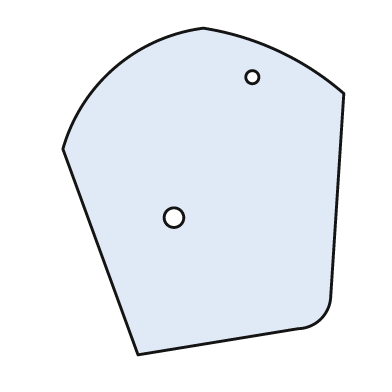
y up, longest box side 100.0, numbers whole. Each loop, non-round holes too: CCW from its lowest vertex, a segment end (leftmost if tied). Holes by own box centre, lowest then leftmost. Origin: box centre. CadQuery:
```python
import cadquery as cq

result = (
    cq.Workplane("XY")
    .moveTo(-20.0, -50.0)
    .lineTo(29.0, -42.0)
    .threePointArc((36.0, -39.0), (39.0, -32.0))
    .lineTo(43.0, 30.0)
    .threePointArc((23.0, 43.0), (0.0, 50.0))
    .threePointArc((-27.0, 38.0), (-43.0, 13.0))
    .close()
    .moveTo(-9.0, -8.0)
    .circle(3.0)
    .moveTo(15.0, 35.0)
    .circle(2.0)
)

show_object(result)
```